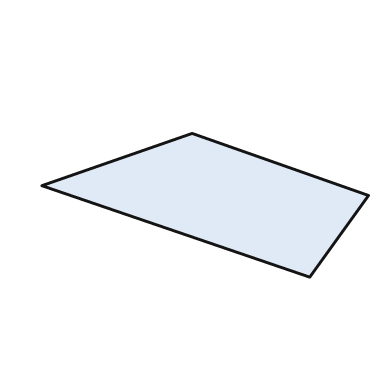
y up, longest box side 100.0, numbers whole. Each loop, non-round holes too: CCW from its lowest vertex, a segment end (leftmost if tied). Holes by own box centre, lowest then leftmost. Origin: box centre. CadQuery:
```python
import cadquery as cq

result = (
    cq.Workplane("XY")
    .moveTo(32.0, -22.0)
    .lineTo(50.0, 3.0)
    .lineTo(-4.0, 22.0)
    .lineTo(-50.0, 6.0)
    .close()
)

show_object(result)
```